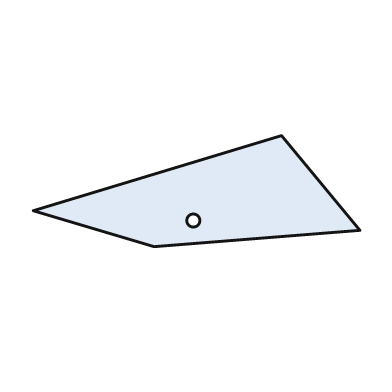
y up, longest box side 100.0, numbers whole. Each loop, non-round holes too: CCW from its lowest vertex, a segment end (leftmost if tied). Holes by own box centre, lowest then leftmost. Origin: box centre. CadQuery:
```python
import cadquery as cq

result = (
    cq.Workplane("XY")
    .moveTo(-13.0, -17.0)
    .lineTo(50.0, -12.0)
    .lineTo(26.0, 17.0)
    .lineTo(-50.0, -6.0)
    .close()
    .moveTo(-1.0, -9.0)
    .circle(2.0)
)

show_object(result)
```